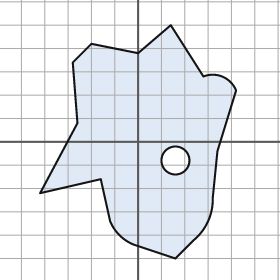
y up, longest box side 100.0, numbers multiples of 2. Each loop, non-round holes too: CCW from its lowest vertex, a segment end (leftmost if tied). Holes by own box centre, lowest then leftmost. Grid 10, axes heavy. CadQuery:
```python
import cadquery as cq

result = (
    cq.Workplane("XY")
    .moveTo(16.0, -50.0)
    .lineTo(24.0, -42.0)
    .threePointArc((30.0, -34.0), (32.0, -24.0))
    .lineTo(34.0, -4.0)
    .lineTo(42.0, 22.0)
    .threePointArc((36.0, 28.0), (28.0, 28.0))
    .lineTo(14.0, 50.0)
    .lineTo(0.0, 38.0)
    .lineTo(-20.0, 42.0)
    .lineTo(-28.0, 34.0)
    .lineTo(-26.0, 8.0)
    .lineTo(-42.0, -22.0)
    .lineTo(-16.0, -16.0)
    .lineTo(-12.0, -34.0)
    .threePointArc((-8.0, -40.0), (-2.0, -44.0))
    .close()
    .moveTo(16.0, -8.0)
    .circle(6.0)
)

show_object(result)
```